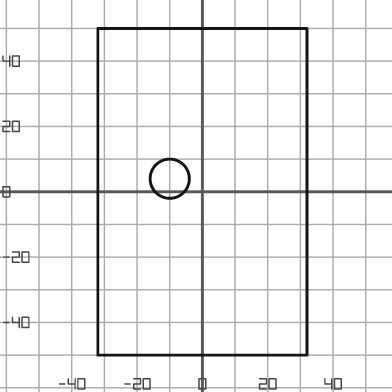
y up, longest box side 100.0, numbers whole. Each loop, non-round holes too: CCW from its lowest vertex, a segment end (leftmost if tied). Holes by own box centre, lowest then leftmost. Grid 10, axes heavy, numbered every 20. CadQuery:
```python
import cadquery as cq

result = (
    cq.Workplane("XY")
    .moveTo(-32.0, -50.0)
    .lineTo(32.0, -50.0)
    .lineTo(32.0, 50.0)
    .lineTo(-32.0, 50.0)
    .close()
    .moveTo(-10.0, 4.0)
    .circle(6.0)
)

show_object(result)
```